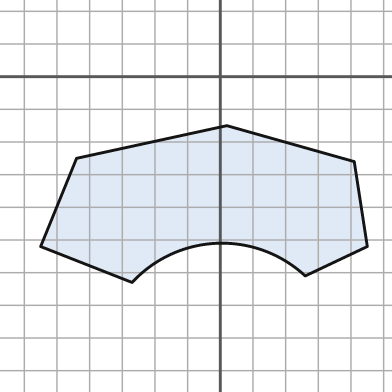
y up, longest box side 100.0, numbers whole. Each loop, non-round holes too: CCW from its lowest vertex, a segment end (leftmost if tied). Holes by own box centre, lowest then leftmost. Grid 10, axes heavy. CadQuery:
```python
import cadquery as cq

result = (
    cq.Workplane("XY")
    .moveTo(-27.0, -63.0)
    .threePointArc((-1.0, -51.0), (26.0, -61.0))
    .lineTo(45.0, -52.0)
    .lineTo(41.0, -26.0)
    .lineTo(2.0, -15.0)
    .lineTo(-44.0, -25.0)
    .lineTo(-55.0, -52.0)
    .close()
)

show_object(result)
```